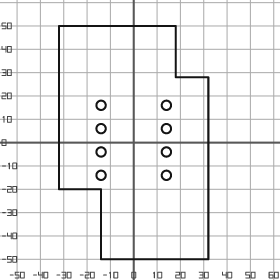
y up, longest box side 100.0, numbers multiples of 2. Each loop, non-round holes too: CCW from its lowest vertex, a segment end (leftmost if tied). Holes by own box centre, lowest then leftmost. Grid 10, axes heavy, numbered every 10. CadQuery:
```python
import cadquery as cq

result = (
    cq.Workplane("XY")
    .moveTo(-14.0, -50.0)
    .lineTo(32.0, -50.0)
    .lineTo(32.0, 28.0)
    .lineTo(18.0, 28.0)
    .lineTo(18.0, 50.0)
    .lineTo(-32.0, 50.0)
    .lineTo(-32.0, -20.0)
    .lineTo(-14.0, -20.0)
    .close()
    .moveTo(-14.0, -14.0)
    .circle(2.0)
    .moveTo(14.0, -14.0)
    .circle(2.0)
    .moveTo(-14.0, -4.0)
    .circle(2.0)
    .moveTo(14.0, -4.0)
    .circle(2.0)
    .moveTo(-14.0, 6.0)
    .circle(2.0)
    .moveTo(14.0, 6.0)
    .circle(2.0)
    .moveTo(-14.0, 16.0)
    .circle(2.0)
    .moveTo(14.0, 16.0)
    .circle(2.0)
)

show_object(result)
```